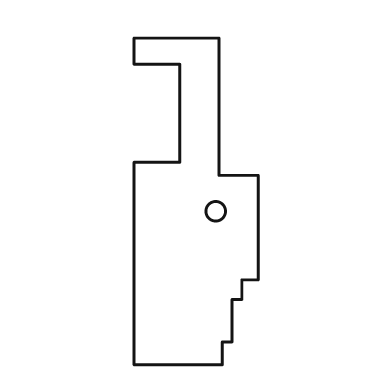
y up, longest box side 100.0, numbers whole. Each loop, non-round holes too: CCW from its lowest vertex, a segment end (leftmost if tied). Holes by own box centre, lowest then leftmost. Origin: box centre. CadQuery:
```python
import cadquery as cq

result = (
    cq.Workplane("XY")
    .moveTo(-19.0, -50.0)
    .lineTo(8.0, -50.0)
    .lineTo(8.0, -43.0)
    .lineTo(11.0, -43.0)
    .lineTo(11.0, -30.0)
    .lineTo(14.0, -30.0)
    .lineTo(14.0, -24.0)
    .lineTo(19.0, -24.0)
    .lineTo(19.0, 8.0)
    .lineTo(7.0, 8.0)
    .lineTo(7.0, 50.0)
    .lineTo(-19.0, 50.0)
    .lineTo(-19.0, 42.0)
    .lineTo(-5.0, 42.0)
    .lineTo(-5.0, 12.0)
    .lineTo(-19.0, 12.0)
    .close()
    .moveTo(6.0, -3.0)
    .circle(3.0)
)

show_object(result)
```